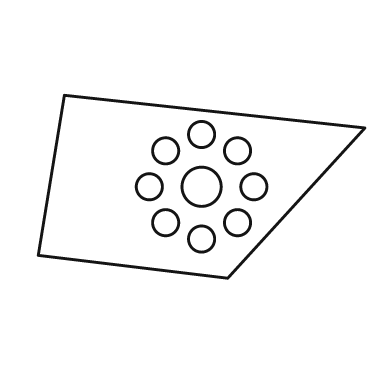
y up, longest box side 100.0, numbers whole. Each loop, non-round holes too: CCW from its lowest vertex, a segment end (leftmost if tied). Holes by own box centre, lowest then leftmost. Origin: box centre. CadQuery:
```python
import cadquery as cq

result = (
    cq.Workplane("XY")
    .moveTo(8.0, -28.0)
    .lineTo(50.0, 18.0)
    .lineTo(-42.0, 28.0)
    .lineTo(-50.0, -21.0)
    .close()
    .moveTo(0.0, -16.0)
    .circle(4.0)
    .moveTo(-11.0, -11.0)
    .circle(4.0)
    .moveTo(11.0, -11.0)
    .circle(4.0)
    .moveTo(-16.0, 0.0)
    .circle(4.0)
    .moveTo(0.0, 0.0)
    .circle(6.0)
    .moveTo(16.0, 0.0)
    .circle(4.0)
    .moveTo(-11.0, 11.0)
    .circle(4.0)
    .moveTo(11.0, 11.0)
    .circle(4.0)
    .moveTo(0.0, 16.0)
    .circle(4.0)
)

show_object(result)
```